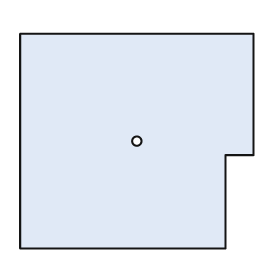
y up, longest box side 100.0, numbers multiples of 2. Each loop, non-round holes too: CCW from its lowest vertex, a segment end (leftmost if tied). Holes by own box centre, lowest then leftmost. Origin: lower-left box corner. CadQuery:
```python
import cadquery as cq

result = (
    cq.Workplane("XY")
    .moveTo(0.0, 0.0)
    .lineTo(88.0, 0.0)
    .lineTo(88.0, 40.0)
    .lineTo(100.0, 40.0)
    .lineTo(100.0, 92.0)
    .lineTo(0.0, 92.0)
    .close()
    .moveTo(50.0, 46.0)
    .circle(2.0)
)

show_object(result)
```